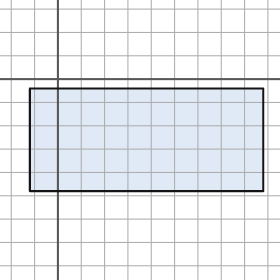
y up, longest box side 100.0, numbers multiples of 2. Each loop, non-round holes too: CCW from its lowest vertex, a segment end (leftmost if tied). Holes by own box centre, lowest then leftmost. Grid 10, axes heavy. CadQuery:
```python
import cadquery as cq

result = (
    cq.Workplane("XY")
    .moveTo(-12.0, -48.0)
    .lineTo(88.0, -48.0)
    .lineTo(88.0, -4.0)
    .lineTo(-12.0, -4.0)
    .close()
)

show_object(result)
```